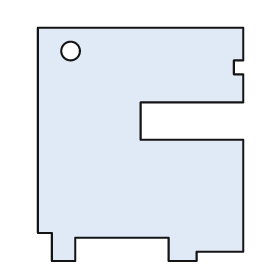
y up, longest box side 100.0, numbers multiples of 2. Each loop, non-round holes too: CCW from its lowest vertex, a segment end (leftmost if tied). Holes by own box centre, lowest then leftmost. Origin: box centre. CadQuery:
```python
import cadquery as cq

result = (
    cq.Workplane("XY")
    .moveTo(-38.0, -50.0)
    .lineTo(-28.0, -50.0)
    .lineTo(-28.0, -40.0)
    .lineTo(12.0, -40.0)
    .lineTo(12.0, -50.0)
    .lineTo(24.0, -50.0)
    .lineTo(24.0, -46.0)
    .lineTo(44.0, -46.0)
    .lineTo(44.0, 2.0)
    .lineTo(0.0, 2.0)
    .lineTo(0.0, 18.0)
    .lineTo(44.0, 18.0)
    .lineTo(44.0, 30.0)
    .lineTo(40.0, 30.0)
    .lineTo(40.0, 36.0)
    .lineTo(44.0, 36.0)
    .lineTo(44.0, 50.0)
    .lineTo(-44.0, 50.0)
    .lineTo(-44.0, -38.0)
    .lineTo(-38.0, -38.0)
    .close()
    .moveTo(-30.0, 40.0)
    .circle(4.0)
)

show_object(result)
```